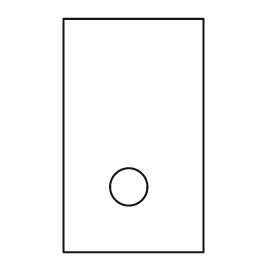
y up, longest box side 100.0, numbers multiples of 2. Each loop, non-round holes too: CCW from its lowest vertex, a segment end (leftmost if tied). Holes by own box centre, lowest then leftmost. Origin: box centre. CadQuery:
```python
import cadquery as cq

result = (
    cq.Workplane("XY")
    .moveTo(-30.0, -50.0)
    .lineTo(30.0, -50.0)
    .lineTo(30.0, 50.0)
    .lineTo(-30.0, 50.0)
    .close()
    .moveTo(-2.0, -22.0)
    .circle(8.0)
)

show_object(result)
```